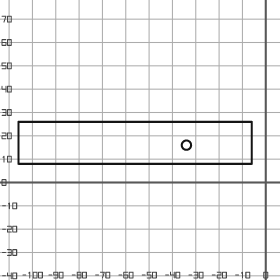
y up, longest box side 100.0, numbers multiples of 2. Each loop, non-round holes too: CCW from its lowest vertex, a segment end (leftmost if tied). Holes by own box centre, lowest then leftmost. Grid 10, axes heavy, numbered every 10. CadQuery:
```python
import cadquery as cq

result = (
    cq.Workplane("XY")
    .moveTo(-106.0, 8.0)
    .lineTo(-6.0, 8.0)
    .lineTo(-6.0, 26.0)
    .lineTo(-106.0, 26.0)
    .close()
    .moveTo(-34.0, 16.0)
    .circle(2.0)
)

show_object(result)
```